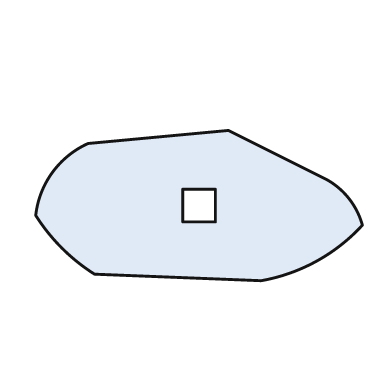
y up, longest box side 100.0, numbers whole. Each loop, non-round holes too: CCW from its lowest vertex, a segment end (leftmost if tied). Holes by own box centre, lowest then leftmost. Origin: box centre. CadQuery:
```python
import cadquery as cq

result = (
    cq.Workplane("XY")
    .moveTo(19.0, -23.0)
    .threePointArc((36.0, -17.0), (50.0, -6.0))
    .threePointArc((46.0, 2.0), (39.0, 8.0))
    .lineTo(9.0, 23.0)
    .lineTo(-34.0, 19.0)
    .threePointArc((-45.0, 10.0), (-50.0, -3.0))
    .threePointArc((-42.0, -13.0), (-32.0, -21.0))
    .close()
    .moveTo(-5.0, -5.0)
    .lineTo(5.0, -5.0)
    .lineTo(5.0, 5.0)
    .lineTo(-5.0, 5.0)
    .close()
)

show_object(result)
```